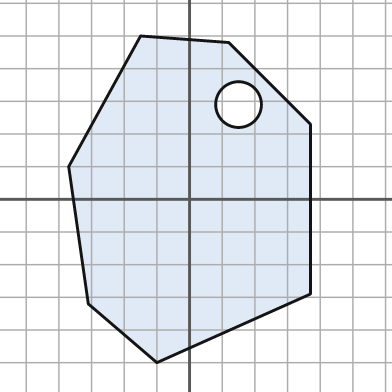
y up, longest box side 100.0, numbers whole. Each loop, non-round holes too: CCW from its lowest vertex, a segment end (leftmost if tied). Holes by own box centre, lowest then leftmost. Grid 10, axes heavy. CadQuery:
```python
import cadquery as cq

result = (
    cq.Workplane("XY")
    .moveTo(-10.0, -50.0)
    .lineTo(37.0, -29.0)
    .lineTo(37.0, 23.0)
    .lineTo(12.0, 48.0)
    .lineTo(-15.0, 50.0)
    .lineTo(-37.0, 10.0)
    .lineTo(-31.0, -32.0)
    .close()
    .moveTo(15.0, 29.0)
    .circle(7.0)
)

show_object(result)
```